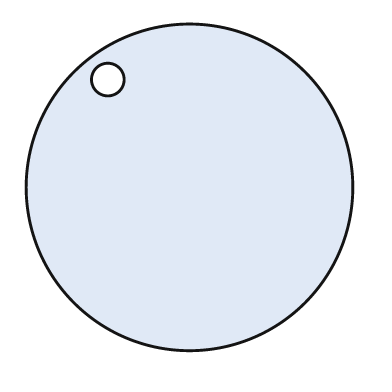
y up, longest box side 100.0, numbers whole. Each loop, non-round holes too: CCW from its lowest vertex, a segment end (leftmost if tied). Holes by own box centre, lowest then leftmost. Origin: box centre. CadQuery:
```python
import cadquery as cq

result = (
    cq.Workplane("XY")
    .moveTo(0.0, 0.0)
    .circle(50.0)
    .moveTo(-25.0, 33.0)
    .circle(5.0)
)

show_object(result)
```